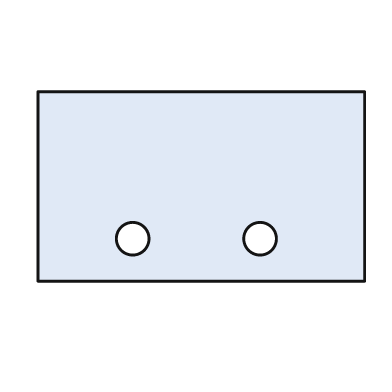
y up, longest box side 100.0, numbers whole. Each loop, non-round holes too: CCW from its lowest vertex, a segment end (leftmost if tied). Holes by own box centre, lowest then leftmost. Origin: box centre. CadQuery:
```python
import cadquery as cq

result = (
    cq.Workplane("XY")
    .moveTo(-50.0, -29.0)
    .lineTo(50.0, -29.0)
    .lineTo(50.0, 29.0)
    .lineTo(-50.0, 29.0)
    .close()
    .moveTo(-21.0, -16.0)
    .circle(5.0)
    .moveTo(18.0, -16.0)
    .circle(5.0)
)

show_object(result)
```